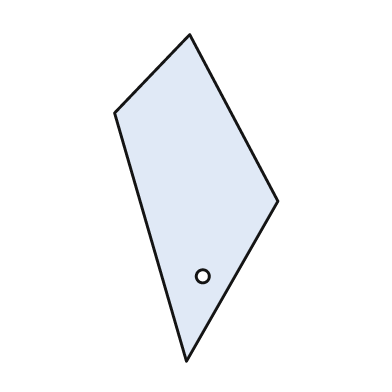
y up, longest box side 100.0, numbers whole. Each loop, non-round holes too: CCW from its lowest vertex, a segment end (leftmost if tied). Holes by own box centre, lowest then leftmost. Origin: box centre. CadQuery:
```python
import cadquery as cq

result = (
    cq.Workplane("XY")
    .moveTo(-3.0, -50.0)
    .lineTo(25.0, -1.0)
    .lineTo(-2.0, 50.0)
    .lineTo(-25.0, 26.0)
    .close()
    .moveTo(2.0, -24.0)
    .circle(2.0)
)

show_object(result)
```